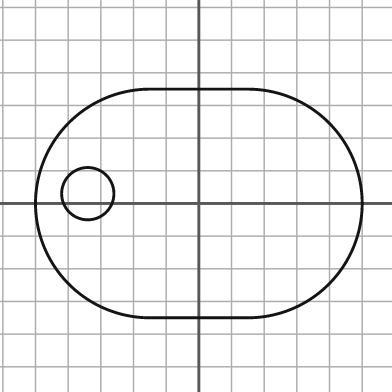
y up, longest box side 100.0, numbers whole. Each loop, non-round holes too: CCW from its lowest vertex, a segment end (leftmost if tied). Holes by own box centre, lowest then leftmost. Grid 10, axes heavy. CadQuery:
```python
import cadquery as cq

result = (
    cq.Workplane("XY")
    .moveTo(-15.0, -35.0)
    .lineTo(15.0, -35.0)
    .threePointArc((50.0, 0.0), (15.0, 35.0))
    .lineTo(-15.0, 35.0)
    .threePointArc((-50.0, 0.0), (-15.0, -35.0))
    .close()
    .moveTo(-34.0, 3.0)
    .circle(8.0)
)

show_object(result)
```